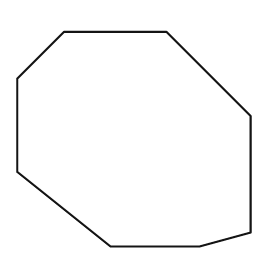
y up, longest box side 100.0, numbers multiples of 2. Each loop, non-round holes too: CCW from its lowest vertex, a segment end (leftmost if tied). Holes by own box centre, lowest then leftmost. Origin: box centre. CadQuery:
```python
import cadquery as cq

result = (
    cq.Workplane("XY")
    .moveTo(-10.0, -46.0)
    .lineTo(28.0, -46.0)
    .lineTo(50.0, -40.0)
    .lineTo(50.0, 10.0)
    .lineTo(14.0, 46.0)
    .lineTo(-30.0, 46.0)
    .lineTo(-50.0, 26.0)
    .lineTo(-50.0, -14.0)
    .close()
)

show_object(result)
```